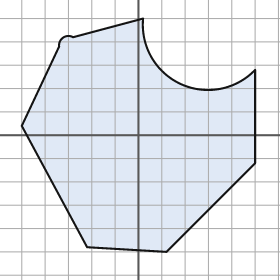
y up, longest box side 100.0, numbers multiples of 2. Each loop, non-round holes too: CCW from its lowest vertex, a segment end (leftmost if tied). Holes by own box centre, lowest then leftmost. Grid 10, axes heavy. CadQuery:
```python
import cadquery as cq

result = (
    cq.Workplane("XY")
    .moveTo(12.0, -50.0)
    .lineTo(50.0, -12.0)
    .lineTo(50.0, 28.0)
    .threePointArc((18.0, 22.0), (2.0, 50.0))
    .lineTo(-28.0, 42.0)
    .threePointArc((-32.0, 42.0), (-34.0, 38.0))
    .lineTo(-50.0, 4.0)
    .lineTo(-22.0, -48.0)
    .close()
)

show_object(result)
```